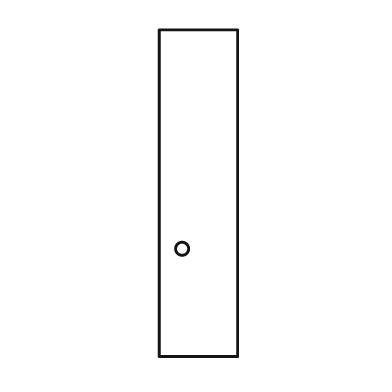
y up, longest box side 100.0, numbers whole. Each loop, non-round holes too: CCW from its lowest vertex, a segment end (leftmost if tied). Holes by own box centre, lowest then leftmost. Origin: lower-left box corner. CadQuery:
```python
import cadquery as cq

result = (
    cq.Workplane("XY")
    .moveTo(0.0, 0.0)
    .lineTo(24.0, 0.0)
    .lineTo(24.0, 100.0)
    .lineTo(0.0, 100.0)
    .close()
    .moveTo(7.0, 33.0)
    .circle(2.0)
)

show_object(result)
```